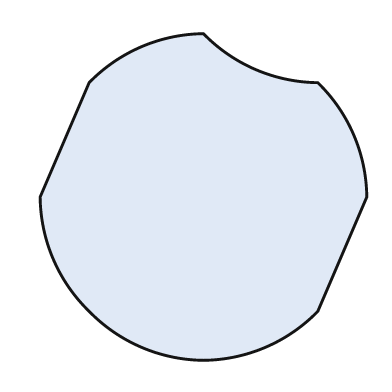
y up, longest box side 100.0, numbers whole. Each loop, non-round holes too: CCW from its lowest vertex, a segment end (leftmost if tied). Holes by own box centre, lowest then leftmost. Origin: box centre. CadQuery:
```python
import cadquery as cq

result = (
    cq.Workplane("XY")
    .moveTo(0.0, -50.0)
    .threePointArc((19.0, -46.0), (35.0, -35.0))
    .lineTo(50.0, 0.0)
    .threePointArc((46.0, 19.0), (35.0, 35.0))
    .threePointArc((16.0, 39.0), (0.0, 50.0))
    .threePointArc((-19.0, 46.0), (-35.0, 35.0))
    .lineTo(-50.0, 0.0)
    .threePointArc((-46.0, -19.0), (-35.0, -35.0))
    .threePointArc((-19.0, -46.0), (0.0, -50.0))
    .close()
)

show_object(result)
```